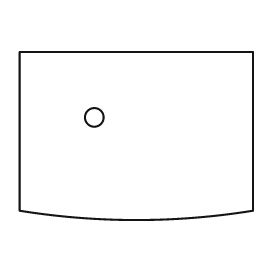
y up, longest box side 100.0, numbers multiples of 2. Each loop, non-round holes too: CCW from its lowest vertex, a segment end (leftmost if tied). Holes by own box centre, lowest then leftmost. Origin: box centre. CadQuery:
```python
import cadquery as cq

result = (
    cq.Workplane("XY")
    .moveTo(-50.0, -32.0)
    .threePointArc((0.0, -36.0), (50.0, -32.0))
    .lineTo(50.0, 36.0)
    .lineTo(-50.0, 36.0)
    .close()
    .moveTo(-18.0, 8.0)
    .circle(4.0)
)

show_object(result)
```